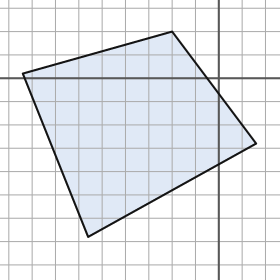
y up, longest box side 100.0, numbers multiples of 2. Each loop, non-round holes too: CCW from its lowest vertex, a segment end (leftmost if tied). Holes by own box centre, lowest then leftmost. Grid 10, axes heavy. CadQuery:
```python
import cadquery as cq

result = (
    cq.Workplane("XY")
    .moveTo(-56.0, -68.0)
    .lineTo(16.0, -28.0)
    .lineTo(-20.0, 20.0)
    .lineTo(-84.0, 2.0)
    .close()
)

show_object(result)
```